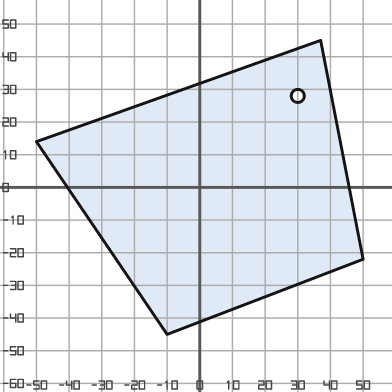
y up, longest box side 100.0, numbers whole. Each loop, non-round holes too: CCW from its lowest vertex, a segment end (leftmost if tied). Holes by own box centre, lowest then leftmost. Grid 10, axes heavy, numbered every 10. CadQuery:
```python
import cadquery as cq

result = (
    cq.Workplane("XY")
    .moveTo(-10.0, -45.0)
    .lineTo(50.0, -22.0)
    .lineTo(37.0, 45.0)
    .lineTo(-50.0, 14.0)
    .close()
    .moveTo(30.0, 28.0)
    .circle(2.0)
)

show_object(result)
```